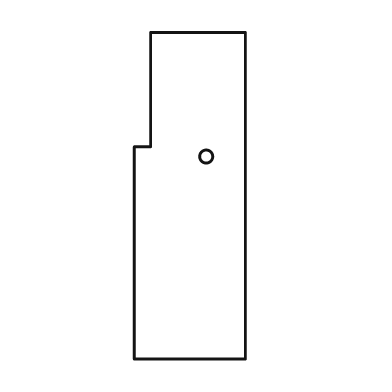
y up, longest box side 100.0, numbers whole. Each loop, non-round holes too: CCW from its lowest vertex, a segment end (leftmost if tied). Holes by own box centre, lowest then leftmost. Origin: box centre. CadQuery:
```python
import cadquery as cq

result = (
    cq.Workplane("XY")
    .moveTo(-17.0, -50.0)
    .lineTo(17.0, -50.0)
    .lineTo(17.0, 50.0)
    .lineTo(-12.0, 50.0)
    .lineTo(-12.0, 15.0)
    .lineTo(-17.0, 15.0)
    .close()
    .moveTo(5.0, 12.0)
    .circle(2.0)
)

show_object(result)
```